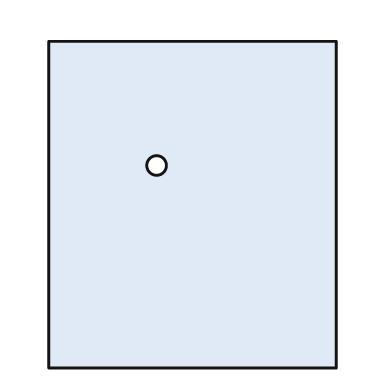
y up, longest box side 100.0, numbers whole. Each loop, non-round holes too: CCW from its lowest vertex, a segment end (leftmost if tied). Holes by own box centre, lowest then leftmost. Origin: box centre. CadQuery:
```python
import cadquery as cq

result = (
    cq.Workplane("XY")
    .moveTo(-44.0, -50.0)
    .lineTo(44.0, -50.0)
    .lineTo(44.0, 50.0)
    .lineTo(-44.0, 50.0)
    .close()
    .moveTo(-11.0, 12.0)
    .circle(3.0)
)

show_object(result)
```